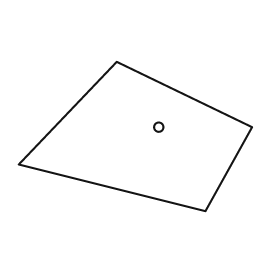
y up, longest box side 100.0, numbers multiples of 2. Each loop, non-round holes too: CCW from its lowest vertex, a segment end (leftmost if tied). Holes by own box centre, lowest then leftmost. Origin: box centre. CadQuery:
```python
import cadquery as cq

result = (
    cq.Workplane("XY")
    .moveTo(30.0, -32.0)
    .lineTo(50.0, 4.0)
    .lineTo(-8.0, 32.0)
    .lineTo(-50.0, -12.0)
    .close()
    .moveTo(10.0, 4.0)
    .circle(2.0)
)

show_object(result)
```